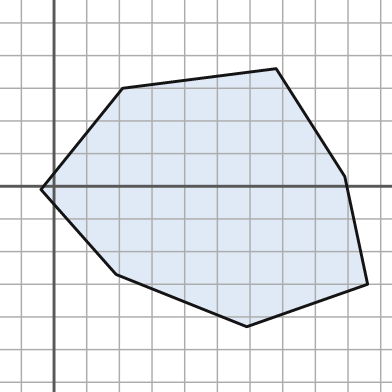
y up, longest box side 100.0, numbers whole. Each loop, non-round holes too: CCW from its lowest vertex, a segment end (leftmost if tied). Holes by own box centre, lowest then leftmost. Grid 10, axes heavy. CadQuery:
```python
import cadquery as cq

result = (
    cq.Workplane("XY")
    .moveTo(59.0, -43.0)
    .lineTo(96.0, -30.0)
    .lineTo(89.0, 3.0)
    .lineTo(68.0, 36.0)
    .lineTo(21.0, 30.0)
    .lineTo(-4.0, -1.0)
    .lineTo(19.0, -27.0)
    .close()
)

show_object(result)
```